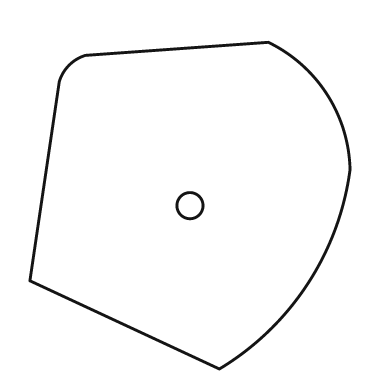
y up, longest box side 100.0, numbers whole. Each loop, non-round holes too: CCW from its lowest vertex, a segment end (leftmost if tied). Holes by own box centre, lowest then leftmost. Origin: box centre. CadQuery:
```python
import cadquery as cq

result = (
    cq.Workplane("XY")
    .moveTo(9.0, -50.0)
    .threePointArc((36.0, -24.0), (49.0, 11.0))
    .threePointArc((42.0, 34.0), (24.0, 50.0))
    .lineTo(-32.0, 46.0)
    .threePointArc((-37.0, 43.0), (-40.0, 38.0))
    .lineTo(-49.0, -23.0)
    .close()
    .moveTo(0.0, 0.0)
    .circle(4.0)
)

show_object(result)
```